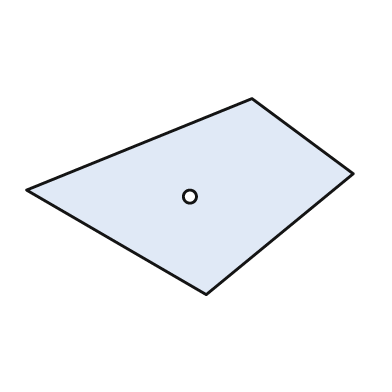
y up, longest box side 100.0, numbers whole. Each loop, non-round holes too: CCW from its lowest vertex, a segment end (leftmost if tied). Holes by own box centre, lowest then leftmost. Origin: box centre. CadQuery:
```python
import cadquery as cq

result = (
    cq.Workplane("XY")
    .moveTo(5.0, -30.0)
    .lineTo(50.0, 7.0)
    .lineTo(19.0, 30.0)
    .lineTo(-50.0, 2.0)
    .close()
    .moveTo(0.0, 0.0)
    .circle(2.0)
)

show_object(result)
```